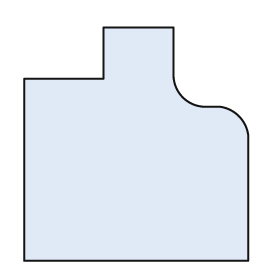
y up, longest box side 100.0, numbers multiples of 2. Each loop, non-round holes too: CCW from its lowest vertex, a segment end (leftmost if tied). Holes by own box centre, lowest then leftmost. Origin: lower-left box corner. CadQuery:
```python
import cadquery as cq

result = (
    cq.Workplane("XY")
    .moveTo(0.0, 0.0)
    .lineTo(96.0, 0.0)
    .lineTo(96.0, 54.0)
    .threePointArc((92.0, 62.0), (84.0, 66.0))
    .lineTo(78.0, 66.0)
    .threePointArc((68.0, 70.0), (64.0, 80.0))
    .lineTo(64.0, 100.0)
    .lineTo(34.0, 100.0)
    .lineTo(34.0, 78.0)
    .lineTo(0.0, 78.0)
    .close()
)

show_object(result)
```